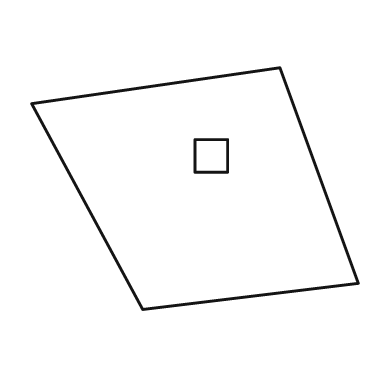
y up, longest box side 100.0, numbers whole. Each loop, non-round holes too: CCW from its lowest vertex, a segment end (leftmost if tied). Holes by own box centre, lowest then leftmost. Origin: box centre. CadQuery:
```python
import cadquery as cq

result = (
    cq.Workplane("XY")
    .moveTo(-16.0, -37.0)
    .lineTo(50.0, -29.0)
    .lineTo(26.0, 37.0)
    .lineTo(-50.0, 26.0)
    .close()
    .moveTo(0.0, 5.0)
    .lineTo(10.0, 5.0)
    .lineTo(10.0, 15.0)
    .lineTo(0.0, 15.0)
    .close()
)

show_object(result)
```